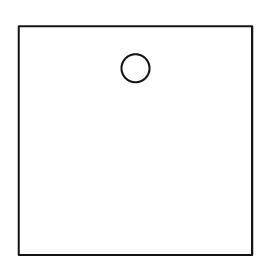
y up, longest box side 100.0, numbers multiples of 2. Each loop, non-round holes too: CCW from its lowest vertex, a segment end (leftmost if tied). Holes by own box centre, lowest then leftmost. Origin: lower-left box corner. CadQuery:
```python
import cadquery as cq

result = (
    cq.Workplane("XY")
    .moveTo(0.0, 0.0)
    .lineTo(100.0, 0.0)
    .lineTo(100.0, 98.0)
    .lineTo(0.0, 98.0)
    .close()
    .moveTo(50.0, 80.0)
    .circle(6.0)
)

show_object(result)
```